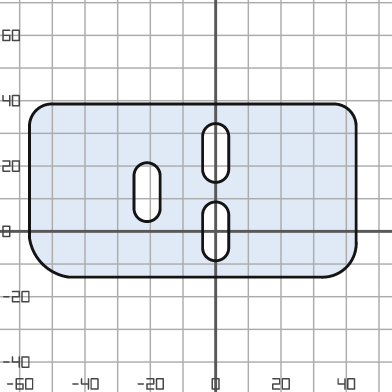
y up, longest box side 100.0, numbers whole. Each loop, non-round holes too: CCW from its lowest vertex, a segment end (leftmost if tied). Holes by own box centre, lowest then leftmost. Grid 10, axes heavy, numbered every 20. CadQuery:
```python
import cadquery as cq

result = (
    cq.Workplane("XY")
    .moveTo(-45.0, -14.0)
    .lineTo(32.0, -14.0)
    .threePointArc((40.0, -11.0), (43.0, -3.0))
    .lineTo(43.0, 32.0)
    .threePointArc((41.0, 37.0), (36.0, 39.0))
    .lineTo(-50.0, 39.0)
    .threePointArc((-55.0, 37.0), (-57.0, 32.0))
    .lineTo(-57.0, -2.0)
    .threePointArc((-53.0, -10.0), (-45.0, -14.0))
    .close()
    .moveTo(-4.0, -5.0)
    .threePointArc((0.0, -9.0), (4.0, -5.0))
    .lineTo(4.0, 5.0)
    .threePointArc((0.0, 9.0), (-4.0, 5.0))
    .close()
    .moveTo(-25.0, 7.0)
    .threePointArc((-21.0, 3.0), (-17.0, 7.0))
    .lineTo(-17.0, 17.0)
    .threePointArc((-21.0, 21.0), (-25.0, 17.0))
    .close()
    .moveTo(-4.0, 19.0)
    .threePointArc((0.0, 15.0), (4.0, 19.0))
    .lineTo(4.0, 29.0)
    .threePointArc((0.0, 33.0), (-4.0, 29.0))
    .close()
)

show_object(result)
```